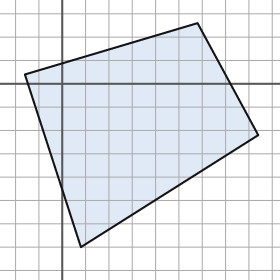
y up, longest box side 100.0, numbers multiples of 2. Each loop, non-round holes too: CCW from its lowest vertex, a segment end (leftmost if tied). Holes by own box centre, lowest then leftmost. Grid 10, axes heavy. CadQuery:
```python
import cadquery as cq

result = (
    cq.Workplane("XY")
    .moveTo(8.0, -70.0)
    .lineTo(84.0, -22.0)
    .lineTo(58.0, 26.0)
    .lineTo(-16.0, 4.0)
    .close()
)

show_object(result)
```